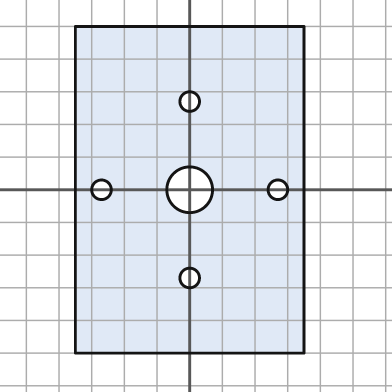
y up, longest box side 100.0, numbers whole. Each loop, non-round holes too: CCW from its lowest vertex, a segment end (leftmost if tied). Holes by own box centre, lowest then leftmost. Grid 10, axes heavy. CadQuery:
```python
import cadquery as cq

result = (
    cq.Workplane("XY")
    .moveTo(-35.0, -50.0)
    .lineTo(35.0, -50.0)
    .lineTo(35.0, 50.0)
    .lineTo(-35.0, 50.0)
    .close()
    .moveTo(0.0, -27.0)
    .circle(3.0)
    .moveTo(-27.0, 0.0)
    .circle(3.0)
    .moveTo(0.0, 0.0)
    .circle(7.0)
    .moveTo(27.0, 0.0)
    .circle(3.0)
    .moveTo(0.0, 27.0)
    .circle(3.0)
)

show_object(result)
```